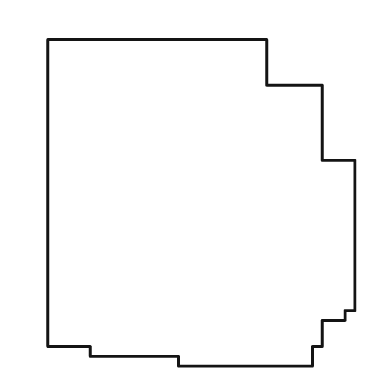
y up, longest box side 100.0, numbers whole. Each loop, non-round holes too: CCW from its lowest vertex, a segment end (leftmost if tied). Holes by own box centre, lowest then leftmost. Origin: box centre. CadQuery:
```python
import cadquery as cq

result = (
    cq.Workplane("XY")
    .moveTo(-7.0, -50.0)
    .lineTo(34.0, -50.0)
    .lineTo(34.0, -44.0)
    .lineTo(37.0, -44.0)
    .lineTo(37.0, -36.0)
    .lineTo(44.0, -36.0)
    .lineTo(44.0, -33.0)
    .lineTo(47.0, -33.0)
    .lineTo(47.0, 13.0)
    .lineTo(37.0, 13.0)
    .lineTo(37.0, 36.0)
    .lineTo(20.0, 36.0)
    .lineTo(20.0, 50.0)
    .lineTo(-47.0, 50.0)
    .lineTo(-47.0, -44.0)
    .lineTo(-34.0, -44.0)
    .lineTo(-34.0, -47.0)
    .lineTo(-7.0, -47.0)
    .close()
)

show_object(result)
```